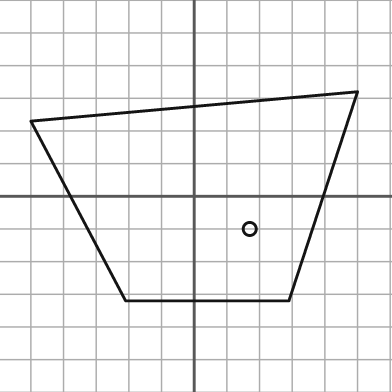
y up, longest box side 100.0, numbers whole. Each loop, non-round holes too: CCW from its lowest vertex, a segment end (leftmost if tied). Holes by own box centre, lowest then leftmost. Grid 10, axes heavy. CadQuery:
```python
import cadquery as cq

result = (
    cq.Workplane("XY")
    .moveTo(-21.0, -32.0)
    .lineTo(29.0, -32.0)
    .lineTo(50.0, 32.0)
    .lineTo(-50.0, 23.0)
    .close()
    .moveTo(17.0, -10.0)
    .circle(2.0)
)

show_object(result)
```